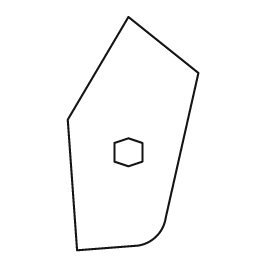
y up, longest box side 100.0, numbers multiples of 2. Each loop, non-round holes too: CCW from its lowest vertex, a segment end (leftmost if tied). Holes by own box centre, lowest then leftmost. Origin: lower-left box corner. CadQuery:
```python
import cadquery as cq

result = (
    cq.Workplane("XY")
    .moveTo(4.0, 0.0)
    .lineTo(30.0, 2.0)
    .threePointArc((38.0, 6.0), (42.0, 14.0))
    .lineTo(56.0, 76.0)
    .lineTo(26.0, 100.0)
    .lineTo(0.0, 56.0)
    .close()
    .moveTo(26.0, 36.0)
    .lineTo(32.0, 38.0)
    .lineTo(32.0, 46.0)
    .lineTo(26.0, 48.0)
    .lineTo(20.0, 46.0)
    .lineTo(20.0, 38.0)
    .close()
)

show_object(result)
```